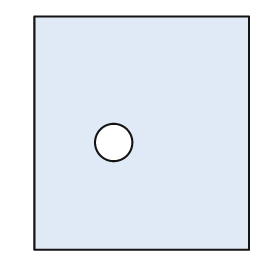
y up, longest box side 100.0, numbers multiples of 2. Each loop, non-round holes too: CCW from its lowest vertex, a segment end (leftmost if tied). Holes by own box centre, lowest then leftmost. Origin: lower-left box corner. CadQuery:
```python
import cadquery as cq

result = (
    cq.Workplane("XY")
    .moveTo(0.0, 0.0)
    .lineTo(92.0, 0.0)
    .lineTo(92.0, 100.0)
    .lineTo(0.0, 100.0)
    .close()
    .moveTo(34.0, 46.0)
    .circle(8.0)
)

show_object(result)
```